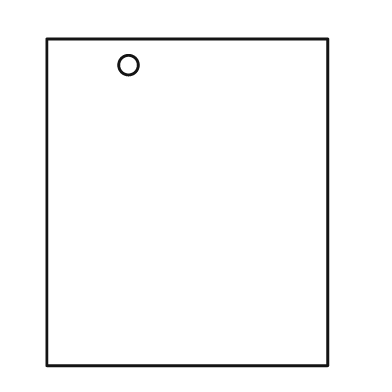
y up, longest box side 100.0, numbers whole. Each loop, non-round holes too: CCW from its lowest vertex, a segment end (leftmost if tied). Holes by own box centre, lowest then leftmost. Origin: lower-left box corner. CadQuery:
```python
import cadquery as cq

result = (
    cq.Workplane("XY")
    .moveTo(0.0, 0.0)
    .lineTo(86.0, 0.0)
    .lineTo(86.0, 100.0)
    .lineTo(0.0, 100.0)
    .close()
    .moveTo(25.0, 92.0)
    .circle(3.0)
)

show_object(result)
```